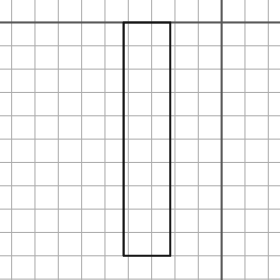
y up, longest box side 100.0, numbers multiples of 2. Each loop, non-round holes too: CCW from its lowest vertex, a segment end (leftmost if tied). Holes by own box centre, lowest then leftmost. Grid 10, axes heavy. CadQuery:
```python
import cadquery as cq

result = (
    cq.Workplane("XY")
    .moveTo(-42.0, -100.0)
    .lineTo(-22.0, -100.0)
    .lineTo(-22.0, 0.0)
    .lineTo(-42.0, 0.0)
    .close()
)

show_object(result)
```